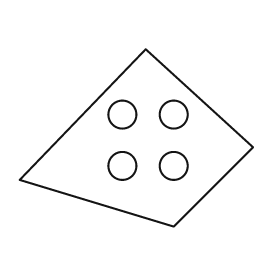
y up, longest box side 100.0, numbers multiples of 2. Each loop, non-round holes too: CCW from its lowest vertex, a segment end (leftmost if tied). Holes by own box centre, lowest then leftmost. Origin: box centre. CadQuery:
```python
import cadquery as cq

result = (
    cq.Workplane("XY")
    .moveTo(16.0, -38.0)
    .lineTo(50.0, -4.0)
    .lineTo(4.0, 38.0)
    .lineTo(-50.0, -18.0)
    .close()
    .moveTo(-6.0, -12.0)
    .circle(6.0)
    .moveTo(16.0, -12.0)
    .circle(6.0)
    .moveTo(-6.0, 10.0)
    .circle(6.0)
    .moveTo(16.0, 10.0)
    .circle(6.0)
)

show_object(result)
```